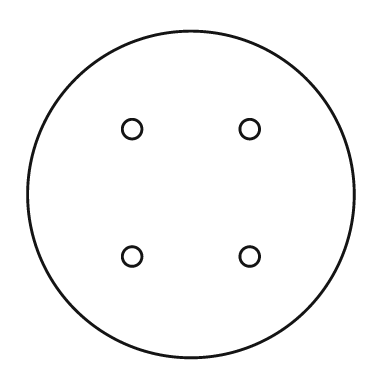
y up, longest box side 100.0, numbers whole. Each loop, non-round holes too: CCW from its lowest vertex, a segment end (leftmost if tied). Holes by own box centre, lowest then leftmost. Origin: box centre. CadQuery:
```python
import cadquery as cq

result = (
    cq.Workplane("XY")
    .moveTo(0.0, 0.0)
    .circle(50.0)
    .moveTo(-18.0, -19.0)
    .circle(3.0)
    .moveTo(18.0, -19.0)
    .circle(3.0)
    .moveTo(-18.0, 20.0)
    .circle(3.0)
    .moveTo(18.0, 20.0)
    .circle(3.0)
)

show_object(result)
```